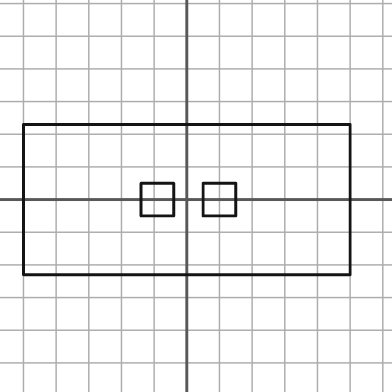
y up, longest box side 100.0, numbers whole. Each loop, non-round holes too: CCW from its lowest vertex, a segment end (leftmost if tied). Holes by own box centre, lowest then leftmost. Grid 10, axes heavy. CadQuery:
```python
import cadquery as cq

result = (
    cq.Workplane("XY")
    .moveTo(-50.0, -23.0)
    .lineTo(50.0, -23.0)
    .lineTo(50.0, 23.0)
    .lineTo(-50.0, 23.0)
    .close()
    .moveTo(-14.0, -5.0)
    .lineTo(-4.0, -5.0)
    .lineTo(-4.0, 5.0)
    .lineTo(-14.0, 5.0)
    .close()
    .moveTo(5.0, -5.0)
    .lineTo(15.0, -5.0)
    .lineTo(15.0, 5.0)
    .lineTo(5.0, 5.0)
    .close()
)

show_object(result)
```